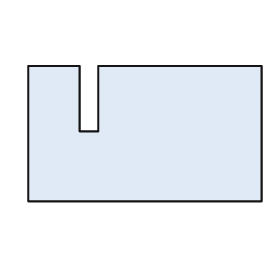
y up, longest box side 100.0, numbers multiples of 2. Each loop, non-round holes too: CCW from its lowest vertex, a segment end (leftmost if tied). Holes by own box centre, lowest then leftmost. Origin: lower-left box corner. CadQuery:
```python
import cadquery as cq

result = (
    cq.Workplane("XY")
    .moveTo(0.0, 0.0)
    .lineTo(100.0, 0.0)
    .lineTo(100.0, 58.0)
    .lineTo(30.0, 58.0)
    .lineTo(30.0, 30.0)
    .lineTo(22.0, 30.0)
    .lineTo(22.0, 58.0)
    .lineTo(0.0, 58.0)
    .close()
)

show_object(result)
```